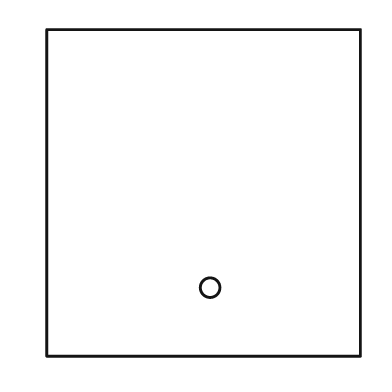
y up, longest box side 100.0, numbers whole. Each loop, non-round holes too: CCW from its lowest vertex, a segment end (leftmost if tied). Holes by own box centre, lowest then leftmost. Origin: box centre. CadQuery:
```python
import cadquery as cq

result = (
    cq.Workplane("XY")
    .moveTo(-48.0, -50.0)
    .lineTo(48.0, -50.0)
    .lineTo(48.0, 50.0)
    .lineTo(-48.0, 50.0)
    .close()
    .moveTo(2.0, -29.0)
    .circle(3.0)
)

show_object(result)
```